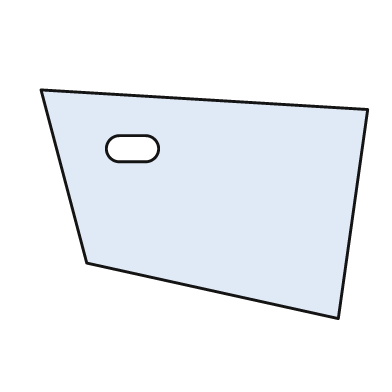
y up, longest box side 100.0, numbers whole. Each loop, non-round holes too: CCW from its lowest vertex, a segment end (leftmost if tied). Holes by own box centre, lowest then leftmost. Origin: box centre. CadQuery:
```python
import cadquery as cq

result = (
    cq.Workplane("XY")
    .moveTo(41.0, -35.0)
    .lineTo(50.0, 29.0)
    .lineTo(-50.0, 35.0)
    .lineTo(-36.0, -18.0)
    .close()
    .moveTo(-26.0, 13.0)
    .lineTo(-18.0, 13.0)
    .threePointArc((-14.0, 17.0), (-18.0, 21.0))
    .lineTo(-26.0, 21.0)
    .threePointArc((-30.0, 17.0), (-26.0, 13.0))
    .close()
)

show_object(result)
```